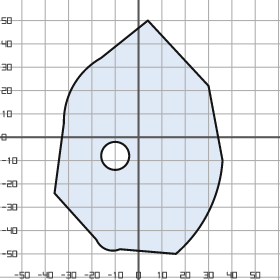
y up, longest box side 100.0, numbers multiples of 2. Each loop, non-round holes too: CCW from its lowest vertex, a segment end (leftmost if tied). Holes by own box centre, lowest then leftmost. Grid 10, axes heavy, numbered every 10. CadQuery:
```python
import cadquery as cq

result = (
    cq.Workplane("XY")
    .moveTo(16.0, -50.0)
    .threePointArc((30.0, -32.0), (36.0, -10.0))
    .lineTo(30.0, 22.0)
    .lineTo(4.0, 50.0)
    .lineTo(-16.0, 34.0)
    .threePointArc((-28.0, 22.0), (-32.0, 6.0))
    .lineTo(-36.0, -24.0)
    .lineTo(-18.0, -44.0)
    .threePointArc((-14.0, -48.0), (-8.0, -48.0))
    .close()
    .moveTo(-10.0, -8.0)
    .circle(6.0)
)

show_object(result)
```